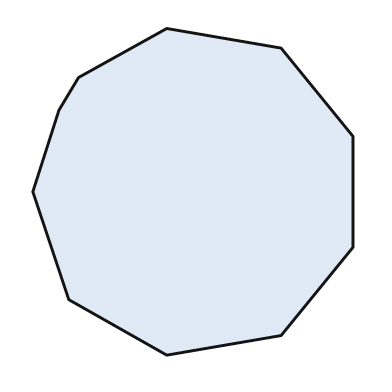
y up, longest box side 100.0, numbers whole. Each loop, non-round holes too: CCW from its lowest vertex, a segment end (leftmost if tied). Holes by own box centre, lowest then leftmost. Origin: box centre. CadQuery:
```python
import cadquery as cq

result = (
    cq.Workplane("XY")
    .moveTo(-8.0, -50.0)
    .lineTo(27.0, -44.0)
    .lineTo(49.0, -17.0)
    .lineTo(49.0, 17.0)
    .lineTo(27.0, 44.0)
    .lineTo(-8.0, 50.0)
    .lineTo(-35.0, 35.0)
    .lineTo(-41.0, 25.0)
    .lineTo(-49.0, 0.0)
    .lineTo(-38.0, -33.0)
    .close()
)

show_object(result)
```